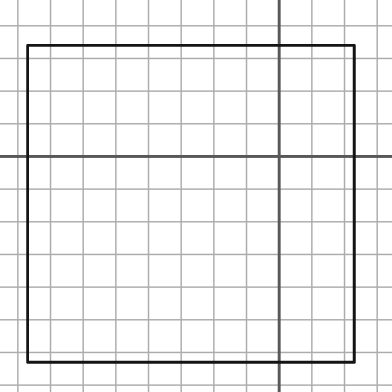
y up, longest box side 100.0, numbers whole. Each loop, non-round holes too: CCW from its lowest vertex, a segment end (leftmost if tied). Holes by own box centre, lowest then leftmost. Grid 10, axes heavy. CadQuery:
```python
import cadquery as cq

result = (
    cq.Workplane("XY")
    .moveTo(-77.0, -63.0)
    .lineTo(23.0, -63.0)
    .lineTo(23.0, 34.0)
    .lineTo(-77.0, 34.0)
    .close()
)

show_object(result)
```